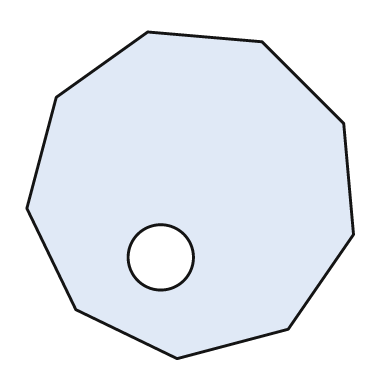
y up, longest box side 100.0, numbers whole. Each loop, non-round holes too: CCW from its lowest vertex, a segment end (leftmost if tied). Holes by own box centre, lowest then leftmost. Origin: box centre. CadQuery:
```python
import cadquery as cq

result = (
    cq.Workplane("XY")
    .moveTo(-4.0, -50.0)
    .lineTo(30.0, -41.0)
    .lineTo(50.0, -12.0)
    .lineTo(47.0, 22.0)
    .lineTo(22.0, 47.0)
    .lineTo(-13.0, 50.0)
    .lineTo(-41.0, 30.0)
    .lineTo(-50.0, -4.0)
    .lineTo(-35.0, -35.0)
    .close()
    .moveTo(-9.0, -19.0)
    .circle(10.0)
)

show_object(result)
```